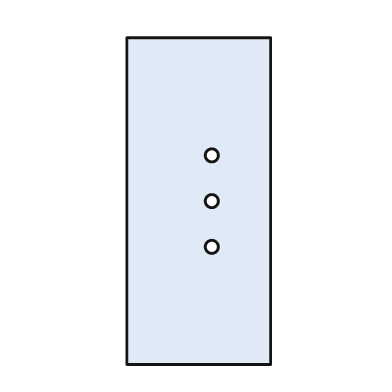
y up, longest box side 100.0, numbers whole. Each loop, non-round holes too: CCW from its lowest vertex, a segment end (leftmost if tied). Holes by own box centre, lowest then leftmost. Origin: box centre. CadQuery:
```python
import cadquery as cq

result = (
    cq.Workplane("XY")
    .moveTo(-22.0, -50.0)
    .lineTo(22.0, -50.0)
    .lineTo(22.0, 50.0)
    .lineTo(-22.0, 50.0)
    .close()
    .moveTo(4.0, -14.0)
    .circle(2.0)
    .moveTo(4.0, 0.0)
    .circle(2.0)
    .moveTo(4.0, 14.0)
    .circle(2.0)
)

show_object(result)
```